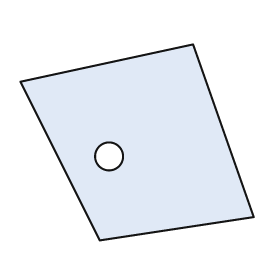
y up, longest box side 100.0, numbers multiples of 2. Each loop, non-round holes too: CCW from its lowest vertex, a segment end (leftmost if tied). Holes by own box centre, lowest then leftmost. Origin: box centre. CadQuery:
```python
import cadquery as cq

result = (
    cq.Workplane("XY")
    .moveTo(-16.0, -42.0)
    .lineTo(50.0, -32.0)
    .lineTo(24.0, 42.0)
    .lineTo(-50.0, 26.0)
    .close()
    .moveTo(-12.0, -6.0)
    .circle(6.0)
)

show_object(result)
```